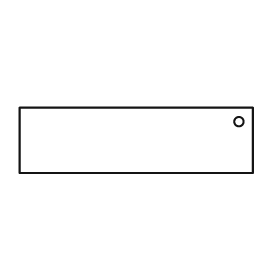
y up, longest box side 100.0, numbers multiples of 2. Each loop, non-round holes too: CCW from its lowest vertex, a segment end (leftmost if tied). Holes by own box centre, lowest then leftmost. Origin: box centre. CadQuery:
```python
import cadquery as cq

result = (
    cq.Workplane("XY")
    .moveTo(-50.0, -14.0)
    .lineTo(50.0, -14.0)
    .lineTo(50.0, 14.0)
    .lineTo(-50.0, 14.0)
    .close()
    .moveTo(44.0, 8.0)
    .circle(2.0)
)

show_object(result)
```